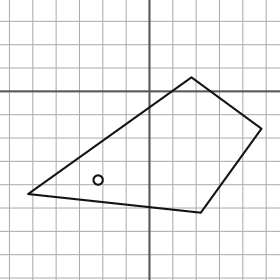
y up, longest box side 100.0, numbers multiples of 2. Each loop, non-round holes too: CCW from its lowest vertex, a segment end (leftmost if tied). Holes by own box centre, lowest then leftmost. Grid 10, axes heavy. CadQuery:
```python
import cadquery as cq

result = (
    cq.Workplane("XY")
    .moveTo(22.0, -52.0)
    .lineTo(48.0, -16.0)
    .lineTo(18.0, 6.0)
    .lineTo(-52.0, -44.0)
    .close()
    .moveTo(-22.0, -38.0)
    .circle(2.0)
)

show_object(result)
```